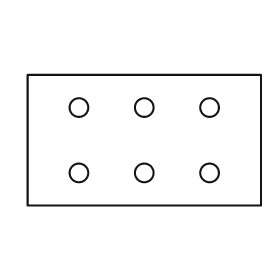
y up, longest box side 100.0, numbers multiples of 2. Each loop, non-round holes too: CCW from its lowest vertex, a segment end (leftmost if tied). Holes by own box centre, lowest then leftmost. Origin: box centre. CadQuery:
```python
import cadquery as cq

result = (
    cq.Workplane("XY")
    .moveTo(-50.0, -28.0)
    .lineTo(50.0, -28.0)
    .lineTo(50.0, 28.0)
    .lineTo(-50.0, 28.0)
    .close()
    .moveTo(-28.0, -14.0)
    .circle(4.0)
    .moveTo(0.0, -14.0)
    .circle(4.0)
    .moveTo(28.0, -14.0)
    .circle(4.0)
    .moveTo(-28.0, 14.0)
    .circle(4.0)
    .moveTo(0.0, 14.0)
    .circle(4.0)
    .moveTo(28.0, 14.0)
    .circle(4.0)
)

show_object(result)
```